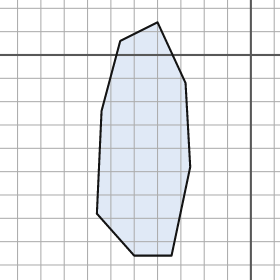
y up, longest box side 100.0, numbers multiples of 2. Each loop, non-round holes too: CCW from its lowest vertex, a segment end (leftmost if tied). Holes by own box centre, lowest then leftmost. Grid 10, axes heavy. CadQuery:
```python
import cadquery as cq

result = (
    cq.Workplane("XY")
    .moveTo(-50.0, -86.0)
    .lineTo(-34.0, -86.0)
    .lineTo(-26.0, -48.0)
    .lineTo(-28.0, -12.0)
    .lineTo(-40.0, 14.0)
    .lineTo(-56.0, 6.0)
    .lineTo(-64.0, -24.0)
    .lineTo(-66.0, -68.0)
    .close()
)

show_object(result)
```